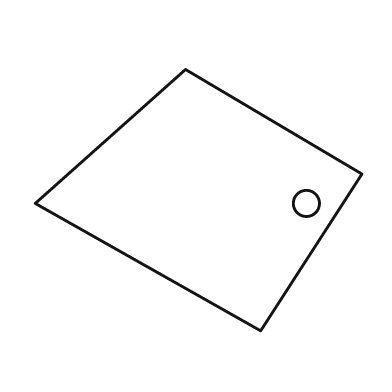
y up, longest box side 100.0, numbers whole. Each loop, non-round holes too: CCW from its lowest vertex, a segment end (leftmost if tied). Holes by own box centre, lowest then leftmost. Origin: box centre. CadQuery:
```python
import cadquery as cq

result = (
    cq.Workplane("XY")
    .moveTo(19.0, -40.0)
    .lineTo(50.0, 8.0)
    .lineTo(-4.0, 40.0)
    .lineTo(-50.0, -1.0)
    .close()
    .moveTo(33.0, -1.0)
    .circle(4.0)
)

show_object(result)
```